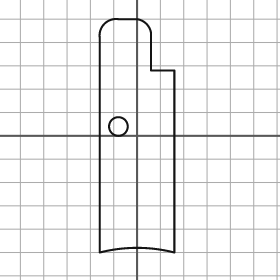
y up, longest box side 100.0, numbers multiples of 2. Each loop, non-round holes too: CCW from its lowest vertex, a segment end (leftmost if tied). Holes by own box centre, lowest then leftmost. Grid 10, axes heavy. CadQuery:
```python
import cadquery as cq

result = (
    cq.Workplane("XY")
    .moveTo(-16.0, -50.0)
    .threePointArc((0.0, -48.0), (16.0, -50.0))
    .lineTo(16.0, 28.0)
    .lineTo(6.0, 28.0)
    .lineTo(6.0, 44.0)
    .threePointArc((4.0, 48.0), (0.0, 50.0))
    .lineTo(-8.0, 50.0)
    .threePointArc((-14.0, 48.0), (-16.0, 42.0))
    .close()
    .moveTo(-8.0, 4.0)
    .circle(4.0)
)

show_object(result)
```